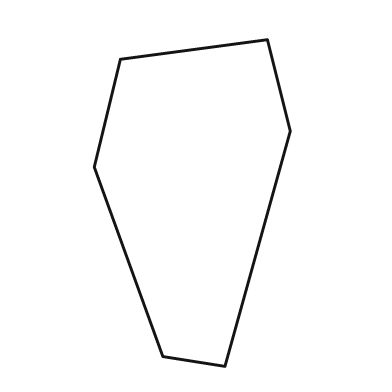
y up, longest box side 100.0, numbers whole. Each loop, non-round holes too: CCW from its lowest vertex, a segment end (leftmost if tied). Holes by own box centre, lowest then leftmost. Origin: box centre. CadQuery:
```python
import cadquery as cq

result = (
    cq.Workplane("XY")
    .moveTo(10.0, -50.0)
    .lineTo(30.0, 22.0)
    .lineTo(23.0, 50.0)
    .lineTo(-22.0, 44.0)
    .lineTo(-30.0, 11.0)
    .lineTo(-9.0, -47.0)
    .close()
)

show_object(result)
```